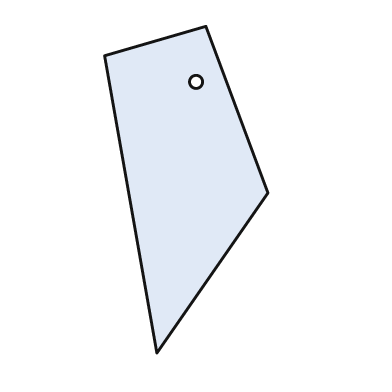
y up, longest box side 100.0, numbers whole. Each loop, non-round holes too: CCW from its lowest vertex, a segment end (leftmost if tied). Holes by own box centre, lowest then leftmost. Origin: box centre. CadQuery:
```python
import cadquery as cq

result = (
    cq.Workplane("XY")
    .moveTo(-9.0, -50.0)
    .lineTo(25.0, -1.0)
    .lineTo(6.0, 50.0)
    .lineTo(-25.0, 41.0)
    .close()
    .moveTo(3.0, 33.0)
    .circle(2.0)
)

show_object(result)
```